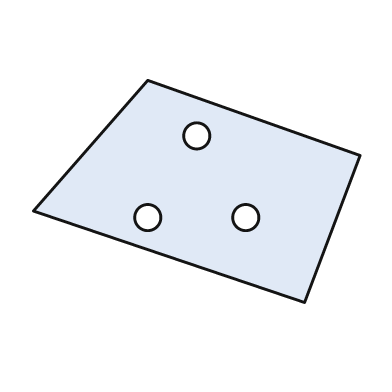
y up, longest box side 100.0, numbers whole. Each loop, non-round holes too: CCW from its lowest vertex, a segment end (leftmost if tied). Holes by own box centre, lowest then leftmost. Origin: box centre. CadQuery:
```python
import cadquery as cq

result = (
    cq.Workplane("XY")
    .moveTo(33.0, -34.0)
    .lineTo(50.0, 11.0)
    .lineTo(-15.0, 34.0)
    .lineTo(-50.0, -6.0)
    .close()
    .moveTo(-15.0, -8.0)
    .circle(4.0)
    .moveTo(15.0, -8.0)
    .circle(4.0)
    .moveTo(0.0, 17.0)
    .circle(4.0)
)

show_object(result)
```